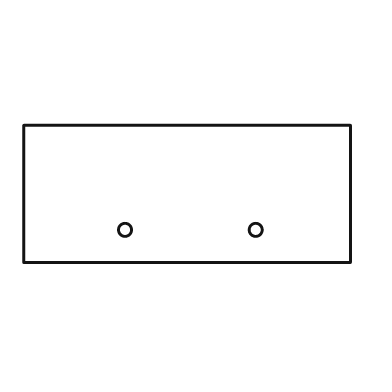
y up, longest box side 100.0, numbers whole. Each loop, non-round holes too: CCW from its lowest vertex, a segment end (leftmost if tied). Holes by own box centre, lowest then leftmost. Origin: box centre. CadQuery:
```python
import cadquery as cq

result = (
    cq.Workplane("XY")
    .moveTo(-50.0, -21.0)
    .lineTo(50.0, -21.0)
    .lineTo(50.0, 21.0)
    .lineTo(-50.0, 21.0)
    .close()
    .moveTo(-19.0, -11.0)
    .circle(2.0)
    .moveTo(21.0, -11.0)
    .circle(2.0)
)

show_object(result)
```